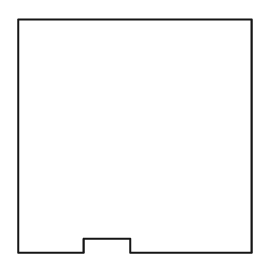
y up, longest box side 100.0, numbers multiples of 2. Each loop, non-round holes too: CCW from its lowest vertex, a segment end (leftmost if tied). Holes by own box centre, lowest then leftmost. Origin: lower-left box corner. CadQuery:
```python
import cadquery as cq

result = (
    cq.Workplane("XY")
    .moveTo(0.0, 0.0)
    .lineTo(28.0, 0.0)
    .lineTo(28.0, 6.0)
    .lineTo(48.0, 6.0)
    .lineTo(48.0, 0.0)
    .lineTo(100.0, 0.0)
    .lineTo(100.0, 100.0)
    .lineTo(0.0, 100.0)
    .close()
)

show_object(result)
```